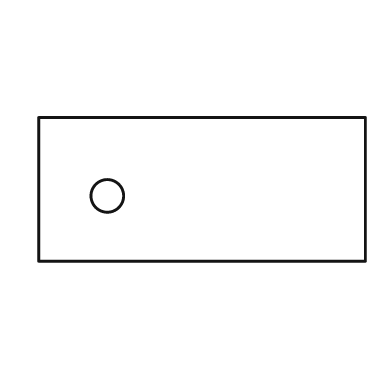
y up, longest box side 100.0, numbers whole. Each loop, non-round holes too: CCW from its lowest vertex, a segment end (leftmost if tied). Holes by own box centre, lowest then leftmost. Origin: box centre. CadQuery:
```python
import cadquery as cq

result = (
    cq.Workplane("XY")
    .moveTo(-50.0, -22.0)
    .lineTo(50.0, -22.0)
    .lineTo(50.0, 22.0)
    .lineTo(-50.0, 22.0)
    .close()
    .moveTo(-29.0, -2.0)
    .circle(5.0)
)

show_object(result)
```